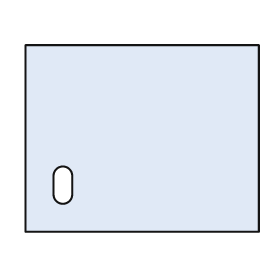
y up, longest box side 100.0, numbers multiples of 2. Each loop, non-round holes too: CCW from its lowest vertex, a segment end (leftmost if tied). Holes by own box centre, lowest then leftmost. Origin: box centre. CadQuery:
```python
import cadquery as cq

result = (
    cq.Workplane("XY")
    .moveTo(-50.0, -40.0)
    .lineTo(50.0, -40.0)
    .lineTo(50.0, 40.0)
    .lineTo(-50.0, 40.0)
    .close()
    .moveTo(-38.0, -24.0)
    .threePointArc((-34.0, -28.0), (-30.0, -24.0))
    .lineTo(-30.0, -16.0)
    .threePointArc((-34.0, -12.0), (-38.0, -16.0))
    .close()
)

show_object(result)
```